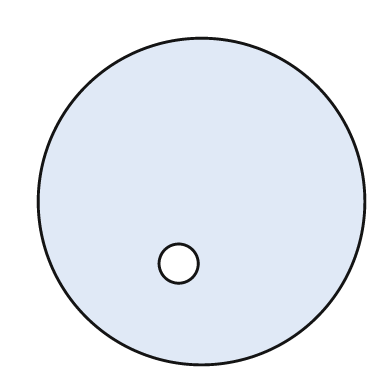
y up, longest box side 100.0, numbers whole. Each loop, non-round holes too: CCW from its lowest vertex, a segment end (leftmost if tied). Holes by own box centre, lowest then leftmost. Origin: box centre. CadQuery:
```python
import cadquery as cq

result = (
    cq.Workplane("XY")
    .moveTo(0.0, 0.0)
    .circle(50.0)
    .moveTo(-7.0, -19.0)
    .circle(6.0)
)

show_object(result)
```